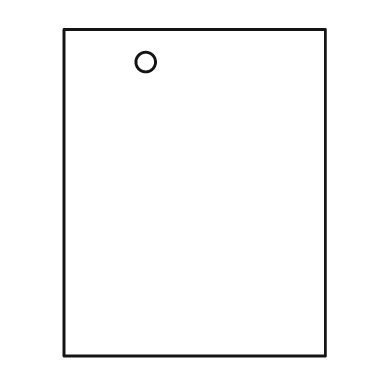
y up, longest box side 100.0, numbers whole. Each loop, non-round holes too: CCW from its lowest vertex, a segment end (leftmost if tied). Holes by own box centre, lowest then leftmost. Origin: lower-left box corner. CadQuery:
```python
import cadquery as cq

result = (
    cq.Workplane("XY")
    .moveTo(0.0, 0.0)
    .lineTo(80.0, 0.0)
    .lineTo(80.0, 100.0)
    .lineTo(0.0, 100.0)
    .close()
    .moveTo(25.0, 90.0)
    .circle(3.0)
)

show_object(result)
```